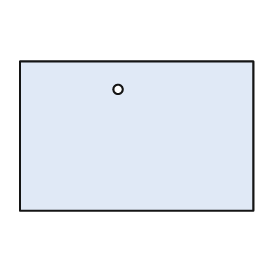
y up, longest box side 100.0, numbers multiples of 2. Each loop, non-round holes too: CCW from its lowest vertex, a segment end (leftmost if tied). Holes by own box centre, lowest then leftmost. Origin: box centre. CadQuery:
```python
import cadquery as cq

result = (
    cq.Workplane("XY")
    .moveTo(-50.0, -32.0)
    .lineTo(50.0, -32.0)
    .lineTo(50.0, 32.0)
    .lineTo(-50.0, 32.0)
    .close()
    .moveTo(-8.0, 20.0)
    .circle(2.0)
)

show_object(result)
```